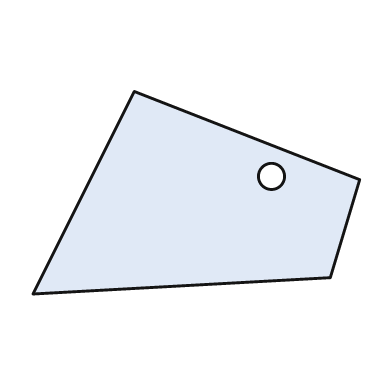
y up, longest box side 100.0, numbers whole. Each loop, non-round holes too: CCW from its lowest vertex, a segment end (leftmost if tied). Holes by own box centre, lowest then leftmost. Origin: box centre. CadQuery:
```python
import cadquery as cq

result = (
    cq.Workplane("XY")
    .moveTo(-50.0, -31.0)
    .lineTo(41.0, -26.0)
    .lineTo(50.0, 4.0)
    .lineTo(-19.0, 31.0)
    .close()
    .moveTo(23.0, 5.0)
    .circle(4.0)
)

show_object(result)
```